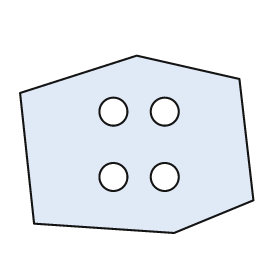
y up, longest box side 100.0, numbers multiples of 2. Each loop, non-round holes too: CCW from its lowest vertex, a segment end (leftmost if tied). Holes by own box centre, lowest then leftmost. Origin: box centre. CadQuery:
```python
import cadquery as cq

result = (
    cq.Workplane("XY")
    .moveTo(16.0, -38.0)
    .lineTo(50.0, -24.0)
    .lineTo(44.0, 28.0)
    .lineTo(0.0, 38.0)
    .lineTo(-50.0, 22.0)
    .lineTo(-44.0, -34.0)
    .close()
    .moveTo(-10.0, -14.0)
    .circle(6.0)
    .moveTo(12.0, -14.0)
    .circle(6.0)
    .moveTo(-10.0, 14.0)
    .circle(6.0)
    .moveTo(12.0, 14.0)
    .circle(6.0)
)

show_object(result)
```